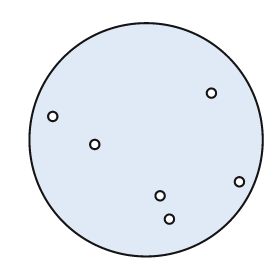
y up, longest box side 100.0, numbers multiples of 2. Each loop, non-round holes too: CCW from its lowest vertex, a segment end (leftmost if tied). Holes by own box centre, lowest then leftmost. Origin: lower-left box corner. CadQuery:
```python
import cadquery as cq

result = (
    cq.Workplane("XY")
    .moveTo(50.0, 50.0)
    .circle(50.0)
    .moveTo(60.0, 16.0)
    .circle(2.0)
    .moveTo(56.0, 26.0)
    .circle(2.0)
    .moveTo(90.0, 32.0)
    .circle(2.0)
    .moveTo(28.0, 48.0)
    .circle(2.0)
    .moveTo(10.0, 60.0)
    .circle(2.0)
    .moveTo(78.0, 70.0)
    .circle(2.0)
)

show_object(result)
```